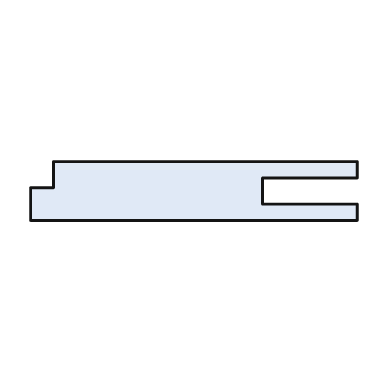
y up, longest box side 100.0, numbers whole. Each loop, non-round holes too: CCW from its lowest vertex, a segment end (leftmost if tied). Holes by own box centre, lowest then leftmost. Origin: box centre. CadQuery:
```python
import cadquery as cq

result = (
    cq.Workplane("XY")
    .moveTo(-50.0, -9.0)
    .lineTo(50.0, -9.0)
    .lineTo(50.0, -4.0)
    .lineTo(21.0, -4.0)
    .lineTo(21.0, 4.0)
    .lineTo(50.0, 4.0)
    .lineTo(50.0, 9.0)
    .lineTo(-43.0, 9.0)
    .lineTo(-43.0, 1.0)
    .lineTo(-50.0, 1.0)
    .close()
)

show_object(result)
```